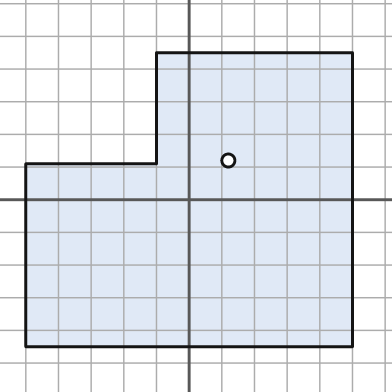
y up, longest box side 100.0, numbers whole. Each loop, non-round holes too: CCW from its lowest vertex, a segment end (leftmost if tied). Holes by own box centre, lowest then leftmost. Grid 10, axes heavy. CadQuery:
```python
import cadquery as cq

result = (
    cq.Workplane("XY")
    .moveTo(-50.0, -45.0)
    .lineTo(50.0, -45.0)
    .lineTo(50.0, 45.0)
    .lineTo(-10.0, 45.0)
    .lineTo(-10.0, 11.0)
    .lineTo(-50.0, 11.0)
    .close()
    .moveTo(12.0, 12.0)
    .circle(2.0)
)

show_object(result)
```